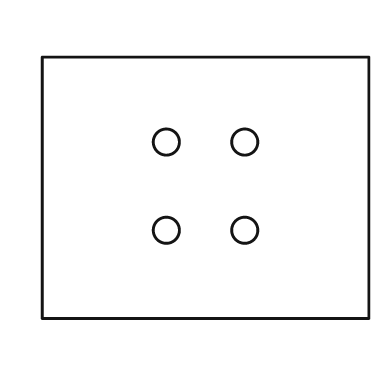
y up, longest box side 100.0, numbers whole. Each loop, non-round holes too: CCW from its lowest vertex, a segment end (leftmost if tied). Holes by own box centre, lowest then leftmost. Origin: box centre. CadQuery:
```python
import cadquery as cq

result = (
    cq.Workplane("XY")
    .moveTo(-50.0, -40.0)
    .lineTo(50.0, -40.0)
    .lineTo(50.0, 40.0)
    .lineTo(-50.0, 40.0)
    .close()
    .moveTo(-12.0, -13.0)
    .circle(4.0)
    .moveTo(12.0, -13.0)
    .circle(4.0)
    .moveTo(-12.0, 14.0)
    .circle(4.0)
    .moveTo(12.0, 14.0)
    .circle(4.0)
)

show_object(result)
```